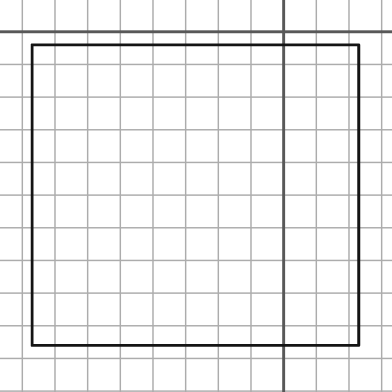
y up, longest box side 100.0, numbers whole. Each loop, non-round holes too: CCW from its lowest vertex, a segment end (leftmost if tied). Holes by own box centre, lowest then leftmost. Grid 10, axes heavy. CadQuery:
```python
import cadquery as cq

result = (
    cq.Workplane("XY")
    .moveTo(-77.0, -96.0)
    .lineTo(23.0, -96.0)
    .lineTo(23.0, -4.0)
    .lineTo(-77.0, -4.0)
    .close()
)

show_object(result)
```